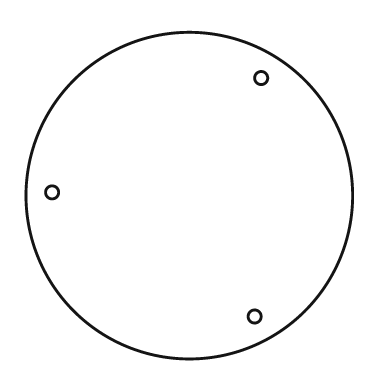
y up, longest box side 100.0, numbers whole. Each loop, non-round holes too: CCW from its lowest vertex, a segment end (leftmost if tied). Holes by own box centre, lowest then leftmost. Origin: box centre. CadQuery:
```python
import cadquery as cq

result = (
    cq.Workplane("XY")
    .moveTo(0.0, 0.0)
    .circle(50.0)
    .moveTo(20.0, -37.0)
    .circle(2.0)
    .moveTo(-42.0, 1.0)
    .circle(2.0)
    .moveTo(22.0, 36.0)
    .circle(2.0)
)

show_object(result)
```